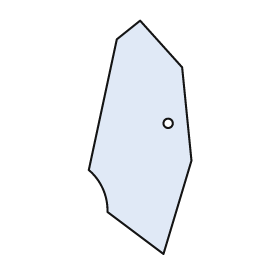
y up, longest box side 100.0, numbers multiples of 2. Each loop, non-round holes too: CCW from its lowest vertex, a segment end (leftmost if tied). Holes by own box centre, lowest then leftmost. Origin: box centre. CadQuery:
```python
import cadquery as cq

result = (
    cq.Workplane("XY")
    .moveTo(10.0, -50.0)
    .lineTo(22.0, -10.0)
    .lineTo(18.0, 30.0)
    .lineTo(0.0, 50.0)
    .lineTo(-10.0, 42.0)
    .lineTo(-22.0, -14.0)
    .threePointArc((-16.0, -22.0), (-14.0, -32.0))
    .close()
    .moveTo(12.0, 6.0)
    .circle(2.0)
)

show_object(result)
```